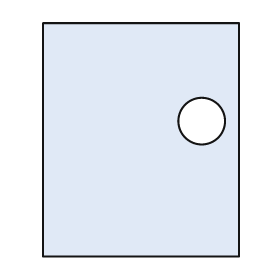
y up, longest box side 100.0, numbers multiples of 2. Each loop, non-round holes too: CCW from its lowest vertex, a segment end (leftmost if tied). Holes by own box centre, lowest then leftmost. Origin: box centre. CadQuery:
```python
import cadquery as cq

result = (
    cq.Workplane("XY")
    .moveTo(-42.0, -50.0)
    .lineTo(42.0, -50.0)
    .lineTo(42.0, 50.0)
    .lineTo(-42.0, 50.0)
    .close()
    .moveTo(26.0, 8.0)
    .circle(10.0)
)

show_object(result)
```